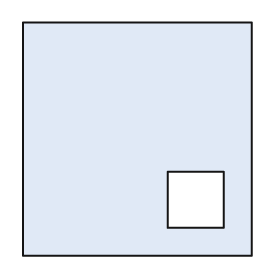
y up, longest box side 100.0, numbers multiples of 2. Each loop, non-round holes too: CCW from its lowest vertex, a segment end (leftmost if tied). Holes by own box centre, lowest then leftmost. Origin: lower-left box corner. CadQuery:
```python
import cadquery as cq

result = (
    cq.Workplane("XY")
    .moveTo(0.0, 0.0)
    .lineTo(98.0, 0.0)
    .lineTo(98.0, 100.0)
    .lineTo(0.0, 100.0)
    .close()
    .moveTo(62.0, 12.0)
    .lineTo(86.0, 12.0)
    .lineTo(86.0, 36.0)
    .lineTo(62.0, 36.0)
    .close()
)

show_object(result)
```